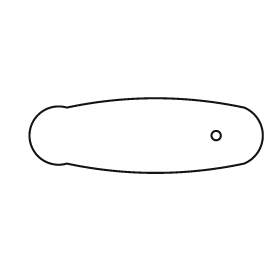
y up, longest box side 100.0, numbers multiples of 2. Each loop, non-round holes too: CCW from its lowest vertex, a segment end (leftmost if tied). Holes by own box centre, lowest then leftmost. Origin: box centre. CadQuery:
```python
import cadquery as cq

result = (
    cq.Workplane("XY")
    .moveTo(-34.0, -12.0)
    .threePointArc((4.0, -16.0), (42.0, -12.0))
    .threePointArc((50.0, 0.0), (42.0, 12.0))
    .threePointArc((4.0, 16.0), (-34.0, 12.0))
    .threePointArc((-50.0, 0.0), (-34.0, -12.0))
    .close()
    .moveTo(30.0, 0.0)
    .circle(2.0)
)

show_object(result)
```